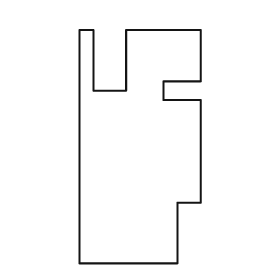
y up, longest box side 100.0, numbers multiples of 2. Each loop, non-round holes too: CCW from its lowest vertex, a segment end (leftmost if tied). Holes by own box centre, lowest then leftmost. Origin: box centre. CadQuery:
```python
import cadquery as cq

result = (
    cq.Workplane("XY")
    .moveTo(-26.0, -50.0)
    .lineTo(16.0, -50.0)
    .lineTo(16.0, -24.0)
    .lineTo(26.0, -24.0)
    .lineTo(26.0, 20.0)
    .lineTo(10.0, 20.0)
    .lineTo(10.0, 28.0)
    .lineTo(26.0, 28.0)
    .lineTo(26.0, 50.0)
    .lineTo(-6.0, 50.0)
    .lineTo(-6.0, 24.0)
    .lineTo(-20.0, 24.0)
    .lineTo(-20.0, 50.0)
    .lineTo(-26.0, 50.0)
    .close()
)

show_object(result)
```